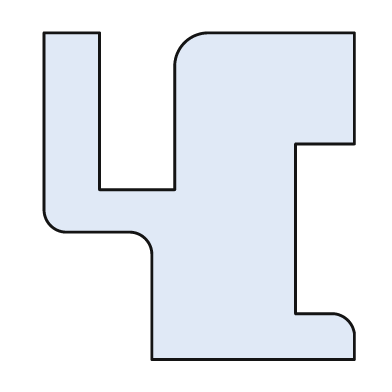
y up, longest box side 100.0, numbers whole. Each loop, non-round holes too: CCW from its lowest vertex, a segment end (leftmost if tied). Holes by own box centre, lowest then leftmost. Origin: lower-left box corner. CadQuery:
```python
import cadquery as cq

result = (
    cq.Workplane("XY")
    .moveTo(33.0, 0.0)
    .lineTo(95.0, 0.0)
    .lineTo(95.0, 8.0)
    .threePointArc((93.0, 12.0), (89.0, 14.0))
    .lineTo(77.0, 14.0)
    .lineTo(77.0, 66.0)
    .lineTo(95.0, 66.0)
    .lineTo(95.0, 100.0)
    .lineTo(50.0, 100.0)
    .threePointArc((43.0, 97.0), (40.0, 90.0))
    .lineTo(40.0, 52.0)
    .lineTo(17.0, 52.0)
    .lineTo(17.0, 100.0)
    .lineTo(0.0, 100.0)
    .lineTo(0.0, 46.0)
    .threePointArc((2.0, 41.0), (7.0, 39.0))
    .lineTo(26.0, 39.0)
    .threePointArc((31.0, 37.0), (33.0, 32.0))
    .close()
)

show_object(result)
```